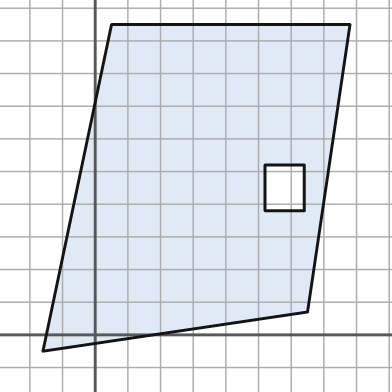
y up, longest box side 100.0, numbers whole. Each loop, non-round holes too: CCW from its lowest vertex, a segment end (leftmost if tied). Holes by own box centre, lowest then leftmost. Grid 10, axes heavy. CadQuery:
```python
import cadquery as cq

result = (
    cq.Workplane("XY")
    .moveTo(-16.0, -5.0)
    .lineTo(65.0, 7.0)
    .lineTo(78.0, 95.0)
    .lineTo(5.0, 95.0)
    .close()
    .moveTo(52.0, 38.0)
    .lineTo(64.0, 38.0)
    .lineTo(64.0, 52.0)
    .lineTo(52.0, 52.0)
    .close()
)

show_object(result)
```